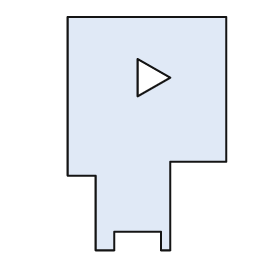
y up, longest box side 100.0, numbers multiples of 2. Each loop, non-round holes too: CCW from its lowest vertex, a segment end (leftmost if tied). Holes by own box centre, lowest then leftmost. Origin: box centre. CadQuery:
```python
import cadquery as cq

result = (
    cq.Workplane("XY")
    .moveTo(-22.0, -50.0)
    .lineTo(-14.0, -50.0)
    .lineTo(-14.0, -42.0)
    .lineTo(6.0, -42.0)
    .lineTo(6.0, -50.0)
    .lineTo(10.0, -50.0)
    .lineTo(10.0, -12.0)
    .lineTo(34.0, -12.0)
    .lineTo(34.0, 50.0)
    .lineTo(-34.0, 50.0)
    .lineTo(-34.0, -18.0)
    .lineTo(-22.0, -18.0)
    .close()
    .moveTo(-4.0, 16.0)
    .lineTo(10.0, 24.0)
    .lineTo(-4.0, 32.0)
    .close()
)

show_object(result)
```